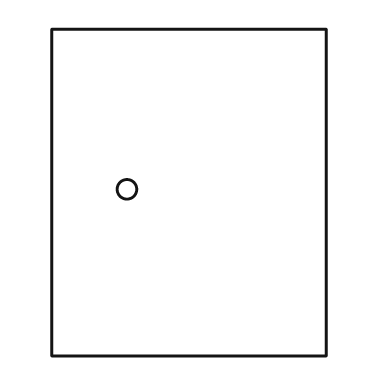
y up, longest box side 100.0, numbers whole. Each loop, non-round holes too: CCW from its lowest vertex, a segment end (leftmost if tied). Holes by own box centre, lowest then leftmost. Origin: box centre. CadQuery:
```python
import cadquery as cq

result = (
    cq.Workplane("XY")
    .moveTo(-42.0, -50.0)
    .lineTo(42.0, -50.0)
    .lineTo(42.0, 50.0)
    .lineTo(-42.0, 50.0)
    .close()
    .moveTo(-19.0, 1.0)
    .circle(3.0)
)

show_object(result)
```